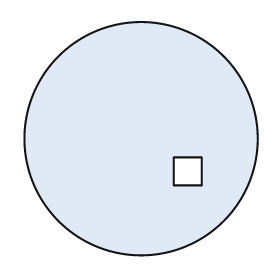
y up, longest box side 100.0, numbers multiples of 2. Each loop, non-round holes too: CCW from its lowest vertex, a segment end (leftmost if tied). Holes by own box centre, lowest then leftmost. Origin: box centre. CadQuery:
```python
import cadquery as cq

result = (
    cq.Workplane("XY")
    .moveTo(0.0, 0.0)
    .circle(50.0)
    .moveTo(14.0, -20.0)
    .lineTo(26.0, -20.0)
    .lineTo(26.0, -8.0)
    .lineTo(14.0, -8.0)
    .close()
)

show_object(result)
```